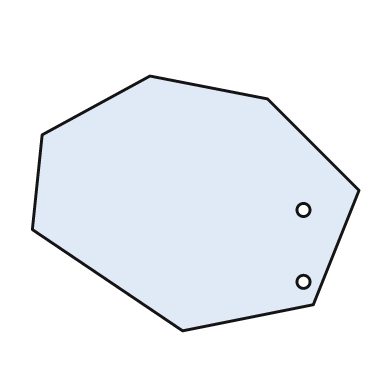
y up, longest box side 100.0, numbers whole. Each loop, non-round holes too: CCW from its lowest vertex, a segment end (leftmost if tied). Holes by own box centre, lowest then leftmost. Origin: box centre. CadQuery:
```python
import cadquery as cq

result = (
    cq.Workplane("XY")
    .moveTo(-4.0, -39.0)
    .lineTo(36.0, -31.0)
    .lineTo(50.0, 4.0)
    .lineTo(22.0, 32.0)
    .lineTo(-14.0, 39.0)
    .lineTo(-47.0, 21.0)
    .lineTo(-50.0, -8.0)
    .close()
    .moveTo(33.0, -24.0)
    .circle(2.0)
    .moveTo(33.0, -2.0)
    .circle(2.0)
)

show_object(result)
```